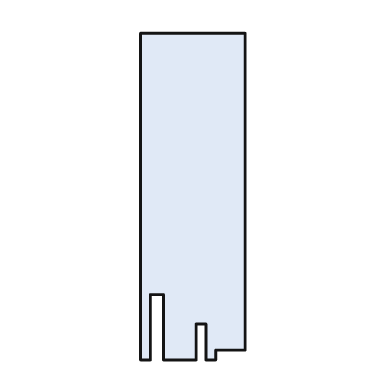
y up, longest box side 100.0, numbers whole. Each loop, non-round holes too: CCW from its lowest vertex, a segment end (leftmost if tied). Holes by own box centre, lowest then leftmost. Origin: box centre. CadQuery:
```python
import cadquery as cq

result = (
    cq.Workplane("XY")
    .moveTo(-16.0, -50.0)
    .lineTo(-13.0, -50.0)
    .lineTo(-13.0, -30.0)
    .lineTo(-9.0, -30.0)
    .lineTo(-9.0, -50.0)
    .lineTo(1.0, -50.0)
    .lineTo(1.0, -39.0)
    .lineTo(4.0, -39.0)
    .lineTo(4.0, -50.0)
    .lineTo(7.0, -50.0)
    .lineTo(7.0, -47.0)
    .lineTo(16.0, -47.0)
    .lineTo(16.0, 50.0)
    .lineTo(-16.0, 50.0)
    .close()
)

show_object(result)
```